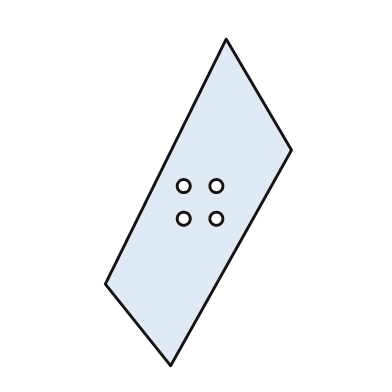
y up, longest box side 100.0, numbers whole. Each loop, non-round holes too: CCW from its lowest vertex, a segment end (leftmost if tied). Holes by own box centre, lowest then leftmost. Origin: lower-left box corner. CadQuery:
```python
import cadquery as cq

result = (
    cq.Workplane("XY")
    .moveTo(20.0, 0.0)
    .lineTo(57.0, 66.0)
    .lineTo(37.0, 100.0)
    .lineTo(0.0, 25.0)
    .close()
    .moveTo(24.0, 45.0)
    .circle(2.0)
    .moveTo(34.0, 45.0)
    .circle(2.0)
    .moveTo(24.0, 55.0)
    .circle(2.0)
    .moveTo(34.0, 55.0)
    .circle(2.0)
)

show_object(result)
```